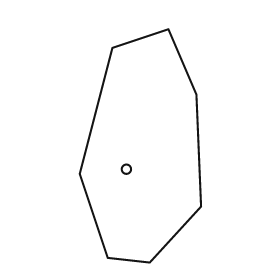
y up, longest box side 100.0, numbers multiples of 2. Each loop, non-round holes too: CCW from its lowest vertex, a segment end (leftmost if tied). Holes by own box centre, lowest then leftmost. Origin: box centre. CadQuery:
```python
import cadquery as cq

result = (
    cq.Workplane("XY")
    .moveTo(4.0, -50.0)
    .lineTo(26.0, -26.0)
    .lineTo(24.0, 22.0)
    .lineTo(12.0, 50.0)
    .lineTo(-12.0, 42.0)
    .lineTo(-26.0, -12.0)
    .lineTo(-14.0, -48.0)
    .close()
    .moveTo(-6.0, -10.0)
    .circle(2.0)
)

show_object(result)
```